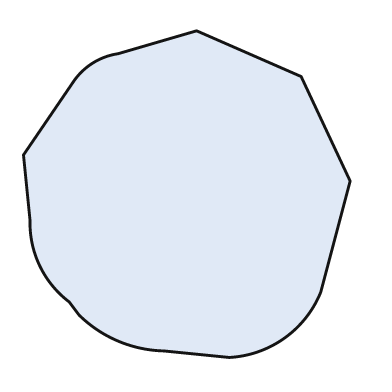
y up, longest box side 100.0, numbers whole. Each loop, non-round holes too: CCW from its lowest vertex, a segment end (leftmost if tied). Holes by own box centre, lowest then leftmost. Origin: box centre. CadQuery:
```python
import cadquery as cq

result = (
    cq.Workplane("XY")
    .moveTo(13.0, -50.0)
    .threePointArc((30.0, -44.0), (41.0, -30.0))
    .lineTo(50.0, 4.0)
    .lineTo(35.0, 36.0)
    .lineTo(3.0, 50.0)
    .lineTo(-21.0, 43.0)
    .threePointArc((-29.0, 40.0), (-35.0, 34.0))
    .lineTo(-50.0, 12.0)
    .lineTo(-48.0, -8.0)
    .threePointArc((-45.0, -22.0), (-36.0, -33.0))
    .lineTo(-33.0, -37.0)
    .threePointArc((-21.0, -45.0), (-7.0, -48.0))
    .close()
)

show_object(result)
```